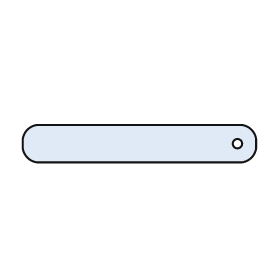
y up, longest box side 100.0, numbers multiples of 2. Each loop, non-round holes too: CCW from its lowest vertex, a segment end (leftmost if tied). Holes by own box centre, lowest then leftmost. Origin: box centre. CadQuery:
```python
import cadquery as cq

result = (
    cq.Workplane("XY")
    .moveTo(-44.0, -8.0)
    .lineTo(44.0, -8.0)
    .threePointArc((48.0, -6.0), (50.0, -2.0))
    .lineTo(50.0, 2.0)
    .threePointArc((48.0, 6.0), (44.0, 8.0))
    .lineTo(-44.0, 8.0)
    .threePointArc((-48.0, 6.0), (-50.0, 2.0))
    .lineTo(-50.0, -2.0)
    .threePointArc((-48.0, -6.0), (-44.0, -8.0))
    .close()
    .moveTo(42.0, 0.0)
    .circle(2.0)
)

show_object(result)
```